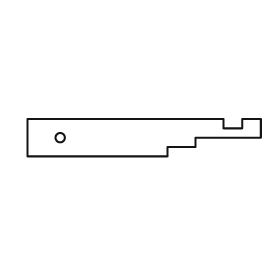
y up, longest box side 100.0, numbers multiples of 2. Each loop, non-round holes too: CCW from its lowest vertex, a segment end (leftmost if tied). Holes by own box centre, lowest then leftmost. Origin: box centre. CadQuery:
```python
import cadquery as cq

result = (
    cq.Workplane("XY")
    .moveTo(-50.0, -8.0)
    .lineTo(10.0, -8.0)
    .lineTo(10.0, -4.0)
    .lineTo(22.0, -4.0)
    .lineTo(22.0, 0.0)
    .lineTo(50.0, 0.0)
    .lineTo(50.0, 8.0)
    .lineTo(42.0, 8.0)
    .lineTo(42.0, 4.0)
    .lineTo(34.0, 4.0)
    .lineTo(34.0, 8.0)
    .lineTo(-50.0, 8.0)
    .close()
    .moveTo(-36.0, 0.0)
    .circle(2.0)
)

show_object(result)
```